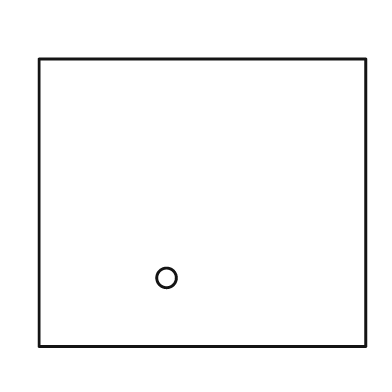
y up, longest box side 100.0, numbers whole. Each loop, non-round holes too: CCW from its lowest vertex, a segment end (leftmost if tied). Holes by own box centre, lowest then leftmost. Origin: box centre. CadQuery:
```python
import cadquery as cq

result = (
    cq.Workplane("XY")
    .moveTo(-50.0, -44.0)
    .lineTo(50.0, -44.0)
    .lineTo(50.0, 44.0)
    .lineTo(-50.0, 44.0)
    .close()
    .moveTo(-11.0, -23.0)
    .circle(3.0)
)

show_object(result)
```